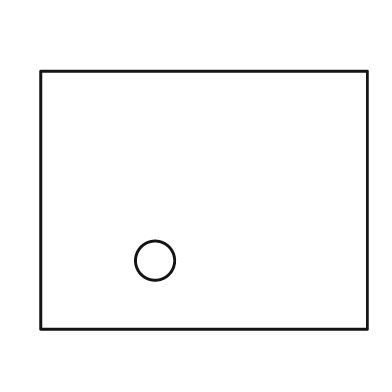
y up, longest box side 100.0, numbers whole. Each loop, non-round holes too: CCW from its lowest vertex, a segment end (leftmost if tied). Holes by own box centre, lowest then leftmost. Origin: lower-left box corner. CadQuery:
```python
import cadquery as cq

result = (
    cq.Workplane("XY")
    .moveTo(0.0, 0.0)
    .lineTo(100.0, 0.0)
    .lineTo(100.0, 79.0)
    .lineTo(0.0, 79.0)
    .close()
    .moveTo(35.0, 21.0)
    .circle(6.0)
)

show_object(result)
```